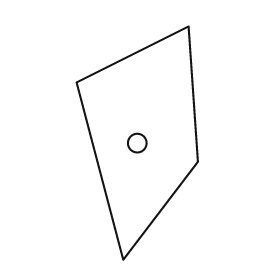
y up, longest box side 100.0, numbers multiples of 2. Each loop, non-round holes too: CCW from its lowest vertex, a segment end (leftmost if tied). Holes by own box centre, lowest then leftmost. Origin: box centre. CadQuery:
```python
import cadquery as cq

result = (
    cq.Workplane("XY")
    .moveTo(-6.0, -50.0)
    .lineTo(26.0, -8.0)
    .lineTo(22.0, 50.0)
    .lineTo(-26.0, 26.0)
    .close()
    .moveTo(0.0, 0.0)
    .circle(4.0)
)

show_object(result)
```